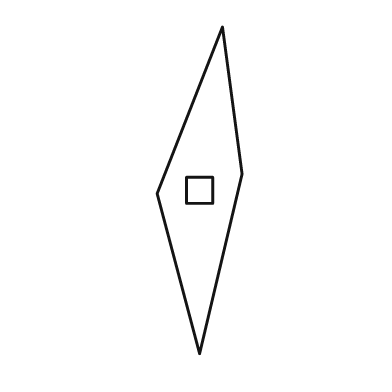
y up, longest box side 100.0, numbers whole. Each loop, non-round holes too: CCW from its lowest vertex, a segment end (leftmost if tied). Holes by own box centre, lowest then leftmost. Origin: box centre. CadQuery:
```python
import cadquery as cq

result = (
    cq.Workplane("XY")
    .moveTo(0.0, -50.0)
    .lineTo(13.0, 5.0)
    .lineTo(7.0, 50.0)
    .lineTo(-13.0, -1.0)
    .close()
    .moveTo(-4.0, -4.0)
    .lineTo(4.0, -4.0)
    .lineTo(4.0, 4.0)
    .lineTo(-4.0, 4.0)
    .close()
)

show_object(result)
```